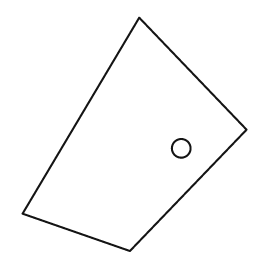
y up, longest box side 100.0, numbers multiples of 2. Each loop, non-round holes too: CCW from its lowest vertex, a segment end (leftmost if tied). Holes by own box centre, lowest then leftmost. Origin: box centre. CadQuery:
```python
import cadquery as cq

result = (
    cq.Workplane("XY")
    .moveTo(-2.0, -50.0)
    .lineTo(48.0, 2.0)
    .lineTo(2.0, 50.0)
    .lineTo(-48.0, -34.0)
    .close()
    .moveTo(20.0, -6.0)
    .circle(4.0)
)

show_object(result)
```